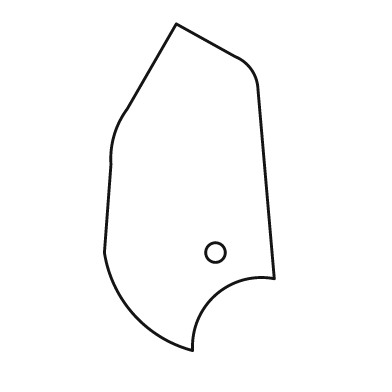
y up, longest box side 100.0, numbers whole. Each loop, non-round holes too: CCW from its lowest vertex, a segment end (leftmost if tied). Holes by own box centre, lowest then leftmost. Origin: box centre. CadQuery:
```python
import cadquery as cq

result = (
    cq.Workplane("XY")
    .moveTo(1.0, -50.0)
    .threePointArc((8.0, -33.0), (26.0, -28.0))
    .lineTo(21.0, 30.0)
    .threePointArc((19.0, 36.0), (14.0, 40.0))
    .lineTo(-4.0, 50.0)
    .lineTo(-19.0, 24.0)
    .threePointArc((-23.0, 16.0), (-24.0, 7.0))
    .lineTo(-26.0, -20.0)
    .threePointArc((-17.0, -39.0), (1.0, -50.0))
    .close()
    .moveTo(8.0, -20.0)
    .circle(3.0)
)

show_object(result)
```